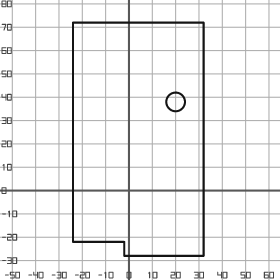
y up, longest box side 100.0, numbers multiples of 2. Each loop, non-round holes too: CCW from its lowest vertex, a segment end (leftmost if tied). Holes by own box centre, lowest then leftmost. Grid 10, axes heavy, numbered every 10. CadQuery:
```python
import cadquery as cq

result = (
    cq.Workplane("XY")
    .moveTo(-2.0, -28.0)
    .lineTo(32.0, -28.0)
    .lineTo(32.0, 72.0)
    .lineTo(-24.0, 72.0)
    .lineTo(-24.0, -22.0)
    .lineTo(-2.0, -22.0)
    .close()
    .moveTo(20.0, 38.0)
    .circle(4.0)
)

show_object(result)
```